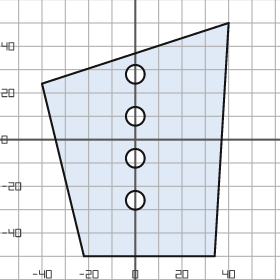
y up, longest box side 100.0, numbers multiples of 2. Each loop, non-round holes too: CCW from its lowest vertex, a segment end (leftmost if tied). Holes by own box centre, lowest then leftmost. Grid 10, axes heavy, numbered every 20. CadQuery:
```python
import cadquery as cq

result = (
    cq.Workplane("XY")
    .moveTo(-22.0, -50.0)
    .lineTo(34.0, -50.0)
    .lineTo(40.0, 50.0)
    .lineTo(-40.0, 24.0)
    .close()
    .moveTo(0.0, -26.0)
    .circle(4.0)
    .moveTo(0.0, -8.0)
    .circle(4.0)
    .moveTo(0.0, 10.0)
    .circle(4.0)
    .moveTo(0.0, 28.0)
    .circle(4.0)
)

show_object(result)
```